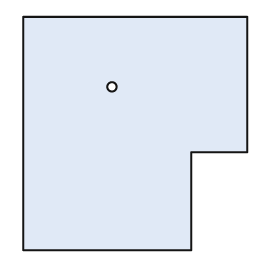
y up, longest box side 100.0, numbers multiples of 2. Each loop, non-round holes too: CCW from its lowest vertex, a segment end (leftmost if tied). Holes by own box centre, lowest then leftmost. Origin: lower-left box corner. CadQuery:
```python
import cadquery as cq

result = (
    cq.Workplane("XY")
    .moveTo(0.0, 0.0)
    .lineTo(72.0, 0.0)
    .lineTo(72.0, 42.0)
    .lineTo(96.0, 42.0)
    .lineTo(96.0, 100.0)
    .lineTo(0.0, 100.0)
    .close()
    .moveTo(38.0, 70.0)
    .circle(2.0)
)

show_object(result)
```